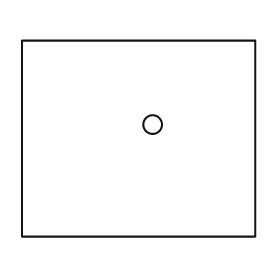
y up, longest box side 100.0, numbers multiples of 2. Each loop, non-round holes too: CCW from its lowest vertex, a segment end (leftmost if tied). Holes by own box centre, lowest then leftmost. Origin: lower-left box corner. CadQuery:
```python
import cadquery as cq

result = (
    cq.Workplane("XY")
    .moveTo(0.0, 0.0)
    .lineTo(100.0, 0.0)
    .lineTo(100.0, 84.0)
    .lineTo(0.0, 84.0)
    .close()
    .moveTo(56.0, 48.0)
    .circle(4.0)
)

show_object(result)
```